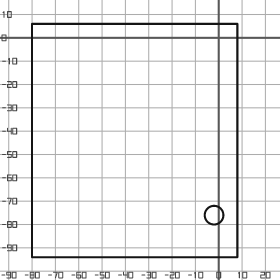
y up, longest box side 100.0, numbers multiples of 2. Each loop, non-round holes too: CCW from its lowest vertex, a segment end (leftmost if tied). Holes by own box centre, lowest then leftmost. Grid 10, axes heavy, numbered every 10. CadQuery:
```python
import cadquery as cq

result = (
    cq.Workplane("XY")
    .moveTo(-80.0, -94.0)
    .lineTo(8.0, -94.0)
    .lineTo(8.0, 6.0)
    .lineTo(-80.0, 6.0)
    .close()
    .moveTo(-2.0, -76.0)
    .circle(4.0)
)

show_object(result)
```